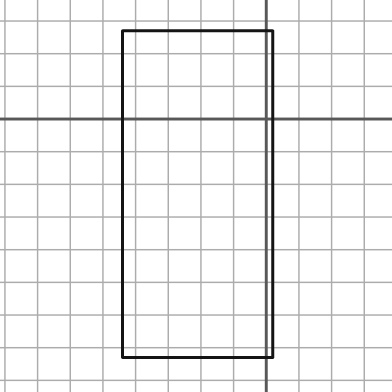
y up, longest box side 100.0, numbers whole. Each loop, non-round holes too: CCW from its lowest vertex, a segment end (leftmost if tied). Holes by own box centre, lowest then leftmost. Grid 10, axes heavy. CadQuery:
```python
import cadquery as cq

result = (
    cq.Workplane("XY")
    .moveTo(-44.0, -73.0)
    .lineTo(2.0, -73.0)
    .lineTo(2.0, 27.0)
    .lineTo(-44.0, 27.0)
    .close()
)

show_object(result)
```